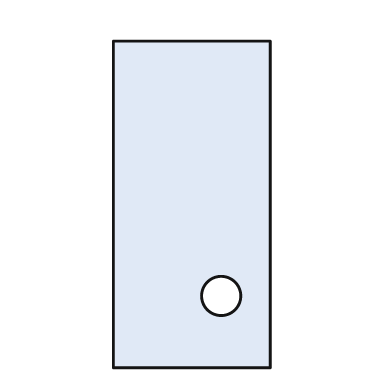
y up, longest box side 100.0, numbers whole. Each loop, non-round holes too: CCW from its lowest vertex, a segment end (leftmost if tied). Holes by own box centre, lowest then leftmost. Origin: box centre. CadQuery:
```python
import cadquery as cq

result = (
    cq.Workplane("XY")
    .moveTo(-24.0, -50.0)
    .lineTo(24.0, -50.0)
    .lineTo(24.0, 50.0)
    .lineTo(-24.0, 50.0)
    .close()
    .moveTo(9.0, -28.0)
    .circle(6.0)
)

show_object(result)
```